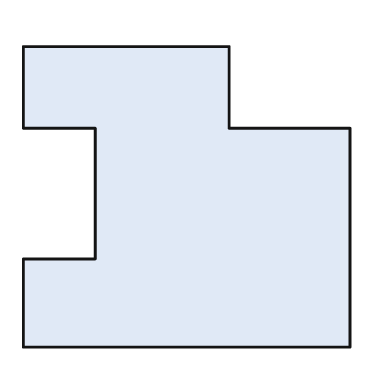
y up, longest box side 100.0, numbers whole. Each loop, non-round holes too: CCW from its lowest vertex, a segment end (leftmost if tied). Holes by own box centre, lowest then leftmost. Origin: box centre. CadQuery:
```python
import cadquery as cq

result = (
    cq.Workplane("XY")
    .moveTo(-50.0, -46.0)
    .lineTo(50.0, -46.0)
    .lineTo(50.0, 21.0)
    .lineTo(13.0, 21.0)
    .lineTo(13.0, 46.0)
    .lineTo(-50.0, 46.0)
    .lineTo(-50.0, 21.0)
    .lineTo(-28.0, 21.0)
    .lineTo(-28.0, -19.0)
    .lineTo(-50.0, -19.0)
    .close()
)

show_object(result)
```